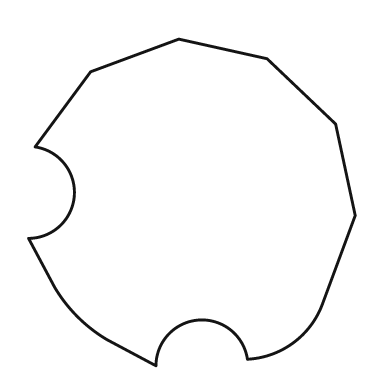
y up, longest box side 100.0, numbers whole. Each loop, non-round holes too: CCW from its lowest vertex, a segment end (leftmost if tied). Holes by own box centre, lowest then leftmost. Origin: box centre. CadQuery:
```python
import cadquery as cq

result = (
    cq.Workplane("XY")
    .moveTo(-11.0, -50.0)
    .threePointArc((2.0, -36.0), (17.0, -48.0))
    .threePointArc((31.0, -43.0), (40.0, -31.0))
    .lineTo(50.0, -4.0)
    .lineTo(44.0, 24.0)
    .lineTo(23.0, 44.0)
    .lineTo(-4.0, 50.0)
    .lineTo(-31.0, 40.0)
    .lineTo(-48.0, 17.0)
    .threePointArc((-36.0, 2.0), (-50.0, -11.0))
    .lineTo(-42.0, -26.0)
    .threePointArc((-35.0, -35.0), (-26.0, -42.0))
    .close()
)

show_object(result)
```